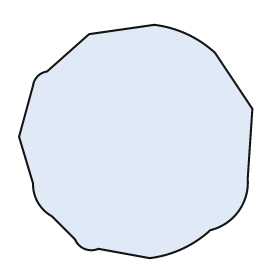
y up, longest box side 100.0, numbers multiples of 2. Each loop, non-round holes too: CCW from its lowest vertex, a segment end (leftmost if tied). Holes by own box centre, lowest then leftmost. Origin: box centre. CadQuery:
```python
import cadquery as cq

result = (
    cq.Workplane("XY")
    .moveTo(6.0, -50.0)
    .threePointArc((20.0, -46.0), (32.0, -38.0))
    .threePointArc((44.0, -30.0), (48.0, -16.0))
    .lineTo(50.0, 14.0)
    .lineTo(34.0, 38.0)
    .threePointArc((22.0, 46.0), (8.0, 50.0))
    .lineTo(-20.0, 46.0)
    .lineTo(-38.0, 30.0)
    .threePointArc((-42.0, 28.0), (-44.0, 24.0))
    .lineTo(-50.0, 2.0)
    .lineTo(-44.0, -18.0)
    .threePointArc((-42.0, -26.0), (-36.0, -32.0))
    .lineTo(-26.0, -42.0)
    .threePointArc((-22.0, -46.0), (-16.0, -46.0))
    .close()
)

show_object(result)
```